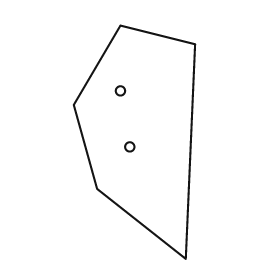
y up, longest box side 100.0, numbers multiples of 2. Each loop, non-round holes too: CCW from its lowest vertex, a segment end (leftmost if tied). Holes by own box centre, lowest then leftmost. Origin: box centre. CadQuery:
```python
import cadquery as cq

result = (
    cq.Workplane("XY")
    .moveTo(22.0, -50.0)
    .lineTo(26.0, 42.0)
    .lineTo(-6.0, 50.0)
    .lineTo(-26.0, 16.0)
    .lineTo(-16.0, -20.0)
    .close()
    .moveTo(-2.0, -2.0)
    .circle(2.0)
    .moveTo(-6.0, 22.0)
    .circle(2.0)
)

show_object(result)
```